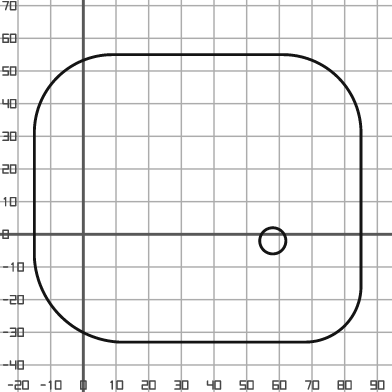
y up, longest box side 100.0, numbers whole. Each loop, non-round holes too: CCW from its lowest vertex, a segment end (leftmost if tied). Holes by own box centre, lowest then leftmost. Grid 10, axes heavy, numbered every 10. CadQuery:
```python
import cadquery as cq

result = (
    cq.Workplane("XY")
    .moveTo(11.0, -33.0)
    .lineTo(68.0, -33.0)
    .threePointArc((80.0, -28.0), (85.0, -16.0))
    .lineTo(85.0, 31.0)
    .threePointArc((78.0, 48.0), (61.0, 55.0))
    .lineTo(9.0, 55.0)
    .threePointArc((-8.0, 48.0), (-15.0, 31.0))
    .lineTo(-15.0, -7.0)
    .threePointArc((-7.0, -25.0), (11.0, -33.0))
    .close()
    .moveTo(58.0, -2.0)
    .circle(4.0)
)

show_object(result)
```